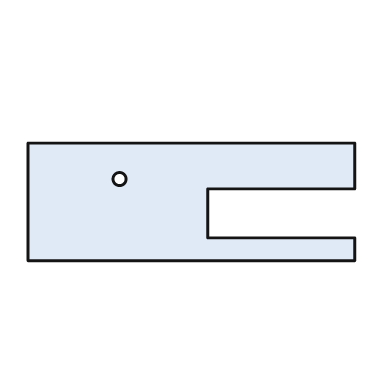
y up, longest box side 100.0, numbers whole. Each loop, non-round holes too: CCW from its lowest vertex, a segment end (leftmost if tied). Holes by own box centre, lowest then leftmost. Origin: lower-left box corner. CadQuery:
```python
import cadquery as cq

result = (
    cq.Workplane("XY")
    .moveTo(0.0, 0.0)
    .lineTo(100.0, 0.0)
    .lineTo(100.0, 7.0)
    .lineTo(55.0, 7.0)
    .lineTo(55.0, 22.0)
    .lineTo(100.0, 22.0)
    .lineTo(100.0, 36.0)
    .lineTo(0.0, 36.0)
    .close()
    .moveTo(28.0, 25.0)
    .circle(2.0)
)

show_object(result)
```